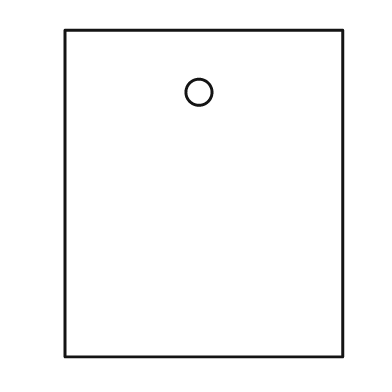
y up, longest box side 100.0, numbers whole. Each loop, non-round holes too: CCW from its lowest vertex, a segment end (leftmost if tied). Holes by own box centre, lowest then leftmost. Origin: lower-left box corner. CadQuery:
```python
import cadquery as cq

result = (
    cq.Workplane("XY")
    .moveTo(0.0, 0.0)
    .lineTo(85.0, 0.0)
    .lineTo(85.0, 100.0)
    .lineTo(0.0, 100.0)
    .close()
    .moveTo(41.0, 81.0)
    .circle(4.0)
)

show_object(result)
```